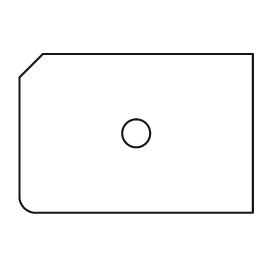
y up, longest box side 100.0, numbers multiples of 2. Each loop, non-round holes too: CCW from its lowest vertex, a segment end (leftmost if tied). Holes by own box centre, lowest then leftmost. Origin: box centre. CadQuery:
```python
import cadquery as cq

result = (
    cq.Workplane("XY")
    .moveTo(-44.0, -34.0)
    .lineTo(50.0, -34.0)
    .lineTo(50.0, 34.0)
    .lineTo(-40.0, 34.0)
    .lineTo(-50.0, 24.0)
    .lineTo(-50.0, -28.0)
    .threePointArc((-48.0, -32.0), (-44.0, -34.0))
    .close()
    .moveTo(0.0, 0.0)
    .circle(6.0)
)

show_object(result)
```